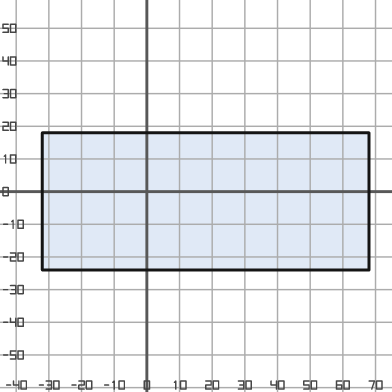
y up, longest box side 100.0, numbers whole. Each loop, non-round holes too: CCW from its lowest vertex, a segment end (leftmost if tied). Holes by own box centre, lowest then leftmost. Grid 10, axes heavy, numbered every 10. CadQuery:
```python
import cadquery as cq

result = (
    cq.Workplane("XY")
    .moveTo(-32.0, -24.0)
    .lineTo(68.0, -24.0)
    .lineTo(68.0, 18.0)
    .lineTo(-32.0, 18.0)
    .close()
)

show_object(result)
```